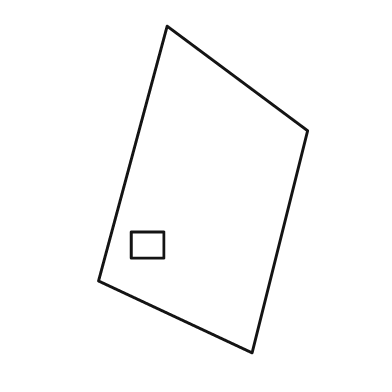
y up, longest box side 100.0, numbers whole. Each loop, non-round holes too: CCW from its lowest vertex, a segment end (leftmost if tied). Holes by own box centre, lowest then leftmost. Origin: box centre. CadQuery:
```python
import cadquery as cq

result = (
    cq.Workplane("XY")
    .moveTo(15.0, -50.0)
    .lineTo(32.0, 18.0)
    .lineTo(-11.0, 50.0)
    .lineTo(-32.0, -28.0)
    .close()
    .moveTo(-22.0, -21.0)
    .lineTo(-12.0, -21.0)
    .lineTo(-12.0, -13.0)
    .lineTo(-22.0, -13.0)
    .close()
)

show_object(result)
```